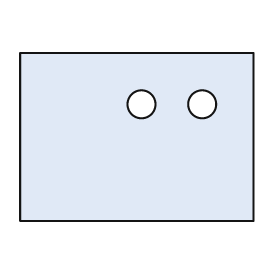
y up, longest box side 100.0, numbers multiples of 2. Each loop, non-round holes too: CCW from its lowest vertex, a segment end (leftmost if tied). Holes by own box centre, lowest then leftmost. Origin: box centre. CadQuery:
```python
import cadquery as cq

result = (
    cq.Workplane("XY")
    .moveTo(-50.0, -36.0)
    .lineTo(50.0, -36.0)
    .lineTo(50.0, 36.0)
    .lineTo(-50.0, 36.0)
    .close()
    .moveTo(2.0, 14.0)
    .circle(6.0)
    .moveTo(28.0, 14.0)
    .circle(6.0)
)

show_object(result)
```